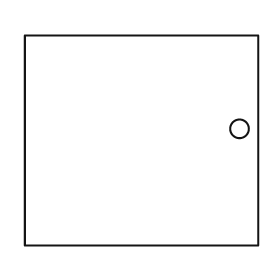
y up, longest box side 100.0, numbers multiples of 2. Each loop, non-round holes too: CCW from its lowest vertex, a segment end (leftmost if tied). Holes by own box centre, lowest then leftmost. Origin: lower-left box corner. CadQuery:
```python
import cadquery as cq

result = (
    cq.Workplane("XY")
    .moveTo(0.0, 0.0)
    .lineTo(100.0, 0.0)
    .lineTo(100.0, 90.0)
    .lineTo(0.0, 90.0)
    .close()
    .moveTo(92.0, 50.0)
    .circle(4.0)
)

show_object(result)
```